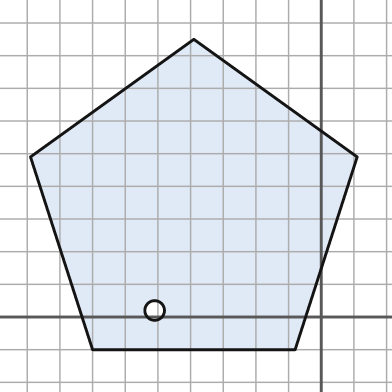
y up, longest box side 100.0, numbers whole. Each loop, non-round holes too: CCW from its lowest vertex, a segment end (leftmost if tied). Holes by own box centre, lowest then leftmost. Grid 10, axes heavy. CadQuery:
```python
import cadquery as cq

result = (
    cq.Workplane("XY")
    .moveTo(-70.0, -10.0)
    .lineTo(-8.0, -10.0)
    .lineTo(11.0, 49.0)
    .lineTo(-39.0, 85.0)
    .lineTo(-89.0, 49.0)
    .close()
    .moveTo(-51.0, 2.0)
    .circle(3.0)
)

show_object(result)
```